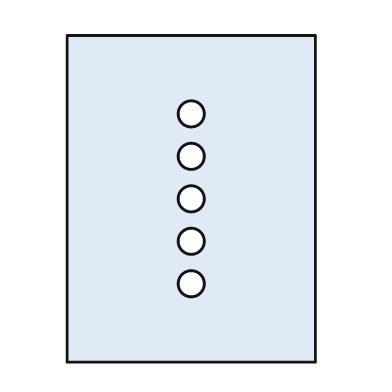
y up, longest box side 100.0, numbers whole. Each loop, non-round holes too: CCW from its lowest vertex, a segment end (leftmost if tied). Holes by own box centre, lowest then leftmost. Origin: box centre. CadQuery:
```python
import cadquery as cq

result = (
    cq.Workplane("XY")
    .moveTo(-38.0, -50.0)
    .lineTo(38.0, -50.0)
    .lineTo(38.0, 50.0)
    .lineTo(-38.0, 50.0)
    .close()
    .moveTo(0.0, -26.0)
    .circle(4.0)
    .moveTo(0.0, -13.0)
    .circle(4.0)
    .moveTo(0.0, 0.0)
    .circle(4.0)
    .moveTo(0.0, 13.0)
    .circle(4.0)
    .moveTo(0.0, 26.0)
    .circle(4.0)
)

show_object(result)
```